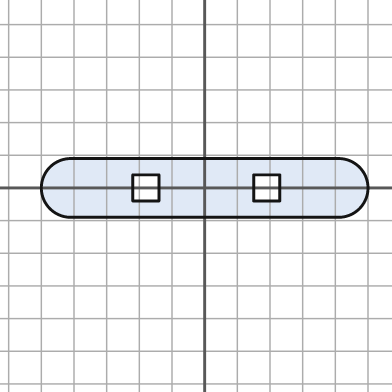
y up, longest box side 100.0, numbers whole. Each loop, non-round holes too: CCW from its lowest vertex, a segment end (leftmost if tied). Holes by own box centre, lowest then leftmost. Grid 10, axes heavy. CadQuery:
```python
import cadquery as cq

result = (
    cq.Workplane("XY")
    .moveTo(-41.0, -9.0)
    .lineTo(41.0, -9.0)
    .threePointArc((50.0, 0.0), (41.0, 9.0))
    .lineTo(-41.0, 9.0)
    .threePointArc((-50.0, 0.0), (-41.0, -9.0))
    .close()
    .moveTo(-22.0, -4.0)
    .lineTo(-14.0, -4.0)
    .lineTo(-14.0, 4.0)
    .lineTo(-22.0, 4.0)
    .close()
    .moveTo(15.0, -4.0)
    .lineTo(23.0, -4.0)
    .lineTo(23.0, 4.0)
    .lineTo(15.0, 4.0)
    .close()
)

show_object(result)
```